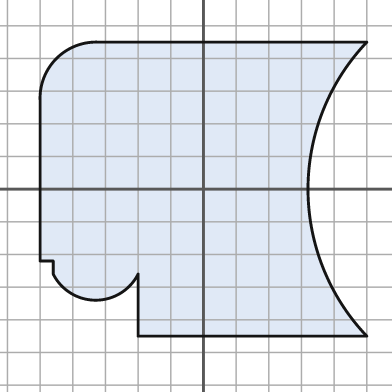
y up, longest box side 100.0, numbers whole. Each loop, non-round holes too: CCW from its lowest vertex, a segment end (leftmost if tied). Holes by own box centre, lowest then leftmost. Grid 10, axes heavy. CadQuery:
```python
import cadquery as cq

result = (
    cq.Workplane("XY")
    .moveTo(-20.0, -45.0)
    .lineTo(50.0, -45.0)
    .threePointArc((32.0, 0.0), (50.0, 45.0))
    .lineTo(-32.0, 45.0)
    .threePointArc((-45.0, 40.0), (-50.0, 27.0))
    .lineTo(-50.0, -22.0)
    .lineTo(-46.0, -22.0)
    .lineTo(-46.0, -26.0)
    .threePointArc((-33.0, -34.0), (-20.0, -26.0))
    .close()
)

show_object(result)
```